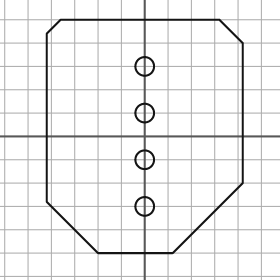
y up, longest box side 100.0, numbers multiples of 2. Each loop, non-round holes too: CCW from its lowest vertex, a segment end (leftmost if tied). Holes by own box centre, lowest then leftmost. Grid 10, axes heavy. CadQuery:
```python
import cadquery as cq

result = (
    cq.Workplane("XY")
    .moveTo(-20.0, -50.0)
    .lineTo(12.0, -50.0)
    .lineTo(42.0, -20.0)
    .lineTo(42.0, 40.0)
    .lineTo(32.0, 50.0)
    .lineTo(-36.0, 50.0)
    .lineTo(-42.0, 44.0)
    .lineTo(-42.0, -28.0)
    .close()
    .moveTo(0.0, -30.0)
    .circle(4.0)
    .moveTo(0.0, -10.0)
    .circle(4.0)
    .moveTo(0.0, 10.0)
    .circle(4.0)
    .moveTo(0.0, 30.0)
    .circle(4.0)
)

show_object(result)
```